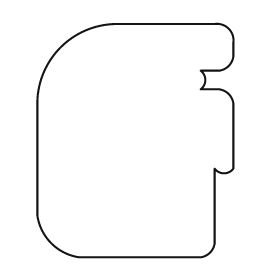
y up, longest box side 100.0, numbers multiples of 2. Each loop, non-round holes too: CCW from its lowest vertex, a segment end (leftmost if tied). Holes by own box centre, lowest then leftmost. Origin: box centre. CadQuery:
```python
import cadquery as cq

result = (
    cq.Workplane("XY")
    .moveTo(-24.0, -50.0)
    .lineTo(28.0, -50.0)
    .threePointArc((32.0, -48.0), (34.0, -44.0))
    .lineTo(34.0, -12.0)
    .threePointArc((38.0, -14.0), (42.0, -12.0))
    .lineTo(42.0, 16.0)
    .threePointArc((40.0, 20.0), (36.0, 22.0))
    .lineTo(28.0, 22.0)
    .threePointArc((30.0, 26.0), (28.0, 30.0))
    .lineTo(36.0, 30.0)
    .threePointArc((40.0, 32.0), (42.0, 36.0))
    .lineTo(42.0, 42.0)
    .threePointArc((40.0, 48.0), (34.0, 50.0))
    .lineTo(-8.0, 50.0)
    .threePointArc((-32.0, 40.0), (-42.0, 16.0))
    .lineTo(-42.0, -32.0)
    .threePointArc((-36.0, -44.0), (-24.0, -50.0))
    .close()
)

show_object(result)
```